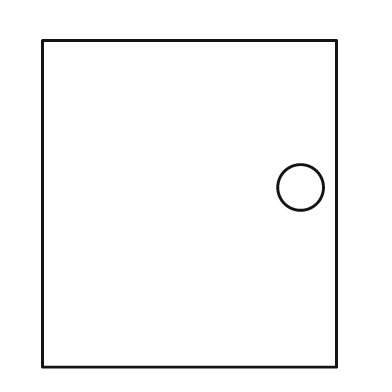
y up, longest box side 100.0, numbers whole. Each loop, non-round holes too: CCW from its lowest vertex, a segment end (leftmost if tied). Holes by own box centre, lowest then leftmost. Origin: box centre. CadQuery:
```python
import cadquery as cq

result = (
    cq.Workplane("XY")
    .moveTo(-45.0, -50.0)
    .lineTo(45.0, -50.0)
    .lineTo(45.0, 50.0)
    .lineTo(-45.0, 50.0)
    .close()
    .moveTo(34.0, 5.0)
    .circle(7.0)
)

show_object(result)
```